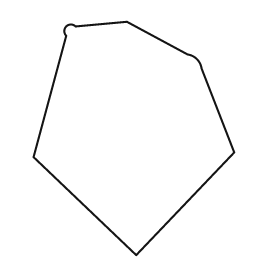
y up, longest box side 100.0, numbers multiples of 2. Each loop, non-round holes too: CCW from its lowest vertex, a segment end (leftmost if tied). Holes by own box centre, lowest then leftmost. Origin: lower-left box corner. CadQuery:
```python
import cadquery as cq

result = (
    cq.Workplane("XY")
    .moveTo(44.0, 0.0)
    .lineTo(86.0, 44.0)
    .lineTo(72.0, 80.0)
    .threePointArc((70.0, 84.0), (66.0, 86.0))
    .lineTo(40.0, 100.0)
    .lineTo(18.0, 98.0)
    .threePointArc((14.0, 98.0), (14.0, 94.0))
    .lineTo(0.0, 42.0)
    .close()
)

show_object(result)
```